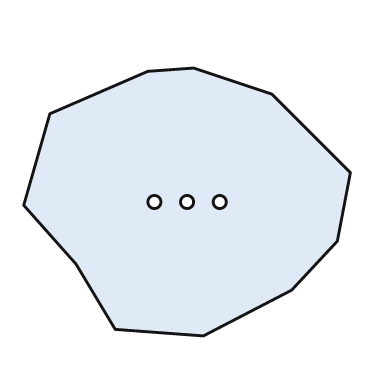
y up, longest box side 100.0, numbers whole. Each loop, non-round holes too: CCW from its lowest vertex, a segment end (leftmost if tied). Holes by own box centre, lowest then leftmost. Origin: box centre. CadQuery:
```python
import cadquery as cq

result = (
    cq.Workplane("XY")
    .moveTo(5.0, -41.0)
    .lineTo(32.0, -27.0)
    .lineTo(46.0, -12.0)
    .lineTo(50.0, 9.0)
    .lineTo(26.0, 33.0)
    .lineTo(2.0, 41.0)
    .lineTo(-12.0, 40.0)
    .lineTo(-42.0, 27.0)
    .lineTo(-50.0, -1.0)
    .lineTo(-34.0, -19.0)
    .lineTo(-22.0, -39.0)
    .close()
    .moveTo(-10.0, 0.0)
    .circle(2.0)
    .moveTo(0.0, 0.0)
    .circle(2.0)
    .moveTo(10.0, 0.0)
    .circle(2.0)
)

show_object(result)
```